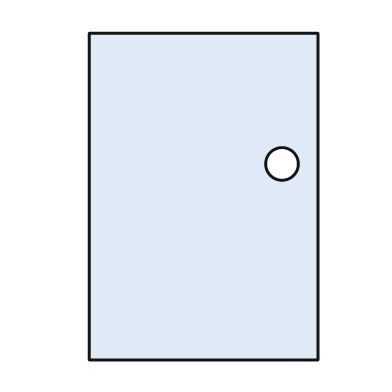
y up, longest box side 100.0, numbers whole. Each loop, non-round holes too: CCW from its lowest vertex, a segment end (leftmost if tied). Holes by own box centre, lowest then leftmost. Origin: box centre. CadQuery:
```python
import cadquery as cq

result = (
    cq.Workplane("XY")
    .moveTo(-35.0, -50.0)
    .lineTo(35.0, -50.0)
    .lineTo(35.0, 50.0)
    .lineTo(-35.0, 50.0)
    .close()
    .moveTo(24.0, 10.0)
    .circle(5.0)
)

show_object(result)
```